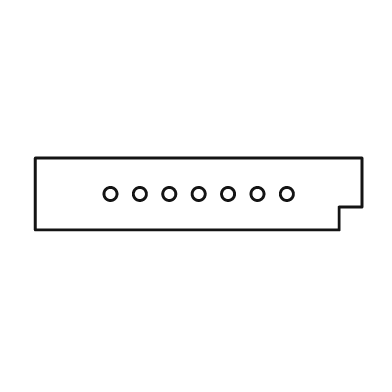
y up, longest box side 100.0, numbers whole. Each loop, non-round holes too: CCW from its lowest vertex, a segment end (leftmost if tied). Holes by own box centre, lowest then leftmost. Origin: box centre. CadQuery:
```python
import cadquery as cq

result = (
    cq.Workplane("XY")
    .moveTo(-50.0, -11.0)
    .lineTo(43.0, -11.0)
    .lineTo(43.0, -4.0)
    .lineTo(50.0, -4.0)
    .lineTo(50.0, 11.0)
    .lineTo(-50.0, 11.0)
    .close()
    .moveTo(-27.0, 0.0)
    .circle(2.0)
    .moveTo(-18.0, 0.0)
    .circle(2.0)
    .moveTo(-9.0, 0.0)
    .circle(2.0)
    .moveTo(0.0, 0.0)
    .circle(2.0)
    .moveTo(9.0, 0.0)
    .circle(2.0)
    .moveTo(18.0, 0.0)
    .circle(2.0)
    .moveTo(27.0, 0.0)
    .circle(2.0)
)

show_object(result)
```